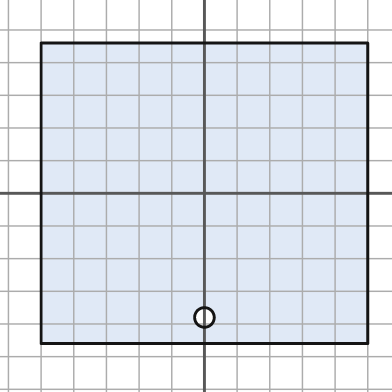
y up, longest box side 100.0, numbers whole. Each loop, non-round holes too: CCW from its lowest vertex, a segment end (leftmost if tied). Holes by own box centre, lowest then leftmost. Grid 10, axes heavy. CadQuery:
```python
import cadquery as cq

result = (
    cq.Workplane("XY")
    .moveTo(-50.0, -46.0)
    .lineTo(50.0, -46.0)
    .lineTo(50.0, 46.0)
    .lineTo(-50.0, 46.0)
    .close()
    .moveTo(0.0, -38.0)
    .circle(3.0)
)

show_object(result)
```